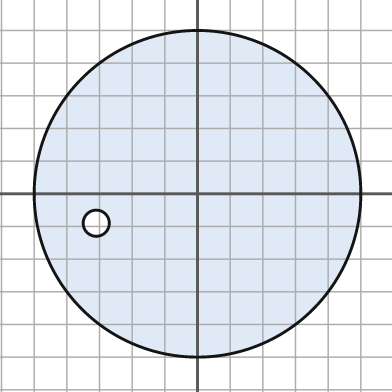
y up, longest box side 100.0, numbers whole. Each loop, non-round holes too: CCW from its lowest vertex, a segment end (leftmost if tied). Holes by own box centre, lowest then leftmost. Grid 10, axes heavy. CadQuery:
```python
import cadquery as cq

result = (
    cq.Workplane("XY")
    .moveTo(0.0, 0.0)
    .circle(50.0)
    .moveTo(-31.0, -9.0)
    .circle(4.0)
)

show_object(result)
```